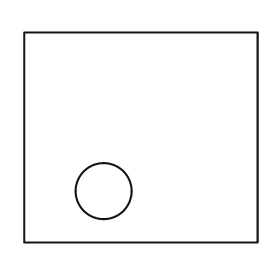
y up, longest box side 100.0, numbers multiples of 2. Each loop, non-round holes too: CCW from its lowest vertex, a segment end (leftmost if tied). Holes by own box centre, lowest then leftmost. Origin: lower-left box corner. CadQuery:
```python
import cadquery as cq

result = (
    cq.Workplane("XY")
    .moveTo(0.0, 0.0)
    .lineTo(100.0, 0.0)
    .lineTo(100.0, 90.0)
    .lineTo(0.0, 90.0)
    .close()
    .moveTo(34.0, 22.0)
    .circle(12.0)
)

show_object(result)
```